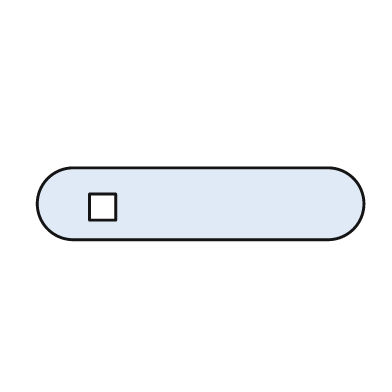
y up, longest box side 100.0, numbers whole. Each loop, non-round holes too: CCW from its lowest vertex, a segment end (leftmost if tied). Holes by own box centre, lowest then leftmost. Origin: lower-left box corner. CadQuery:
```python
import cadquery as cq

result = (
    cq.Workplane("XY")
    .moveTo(11.0, 0.0)
    .lineTo(89.0, 0.0)
    .threePointArc((100.0, 11.0), (89.0, 22.0))
    .lineTo(11.0, 22.0)
    .threePointArc((0.0, 11.0), (11.0, 0.0))
    .close()
    .moveTo(16.0, 6.0)
    .lineTo(24.0, 6.0)
    .lineTo(24.0, 14.0)
    .lineTo(16.0, 14.0)
    .close()
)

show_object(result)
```